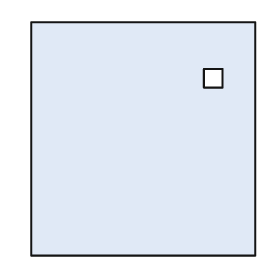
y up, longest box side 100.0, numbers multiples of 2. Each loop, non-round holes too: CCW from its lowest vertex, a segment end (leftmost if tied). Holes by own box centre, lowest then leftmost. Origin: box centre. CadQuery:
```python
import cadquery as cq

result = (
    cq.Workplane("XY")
    .moveTo(-48.0, -50.0)
    .lineTo(48.0, -50.0)
    .lineTo(48.0, 50.0)
    .lineTo(-48.0, 50.0)
    .close()
    .moveTo(26.0, 22.0)
    .lineTo(34.0, 22.0)
    .lineTo(34.0, 30.0)
    .lineTo(26.0, 30.0)
    .close()
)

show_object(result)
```